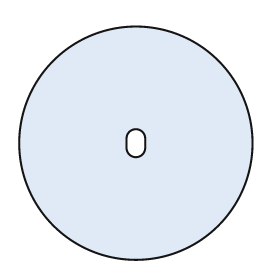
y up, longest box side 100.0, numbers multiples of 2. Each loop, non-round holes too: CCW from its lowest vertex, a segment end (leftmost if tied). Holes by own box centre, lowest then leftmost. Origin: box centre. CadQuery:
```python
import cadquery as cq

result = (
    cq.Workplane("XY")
    .moveTo(0.0, 0.0)
    .circle(50.0)
    .moveTo(-4.0, -2.0)
    .threePointArc((0.0, -6.0), (4.0, -2.0))
    .lineTo(4.0, 2.0)
    .threePointArc((0.0, 6.0), (-4.0, 2.0))
    .close()
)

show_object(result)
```